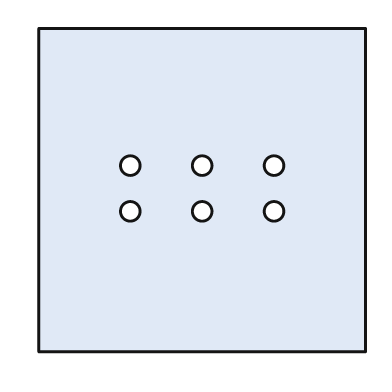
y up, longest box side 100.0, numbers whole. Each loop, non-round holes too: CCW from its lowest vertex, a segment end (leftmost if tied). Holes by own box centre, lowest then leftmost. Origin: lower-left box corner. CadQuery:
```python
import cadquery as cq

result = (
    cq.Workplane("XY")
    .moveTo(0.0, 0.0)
    .lineTo(100.0, 0.0)
    .lineTo(100.0, 99.0)
    .lineTo(0.0, 99.0)
    .close()
    .moveTo(28.0, 43.0)
    .circle(3.0)
    .moveTo(50.0, 43.0)
    .circle(3.0)
    .moveTo(72.0, 43.0)
    .circle(3.0)
    .moveTo(28.0, 57.0)
    .circle(3.0)
    .moveTo(50.0, 57.0)
    .circle(3.0)
    .moveTo(72.0, 57.0)
    .circle(3.0)
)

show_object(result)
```